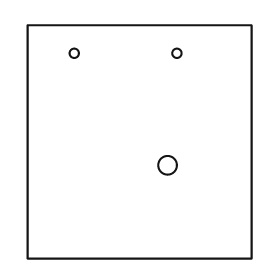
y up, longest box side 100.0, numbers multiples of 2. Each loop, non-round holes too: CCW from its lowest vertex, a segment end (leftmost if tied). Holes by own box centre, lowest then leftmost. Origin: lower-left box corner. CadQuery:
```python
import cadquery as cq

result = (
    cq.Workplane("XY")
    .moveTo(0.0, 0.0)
    .lineTo(96.0, 0.0)
    .lineTo(96.0, 100.0)
    .lineTo(0.0, 100.0)
    .close()
    .moveTo(60.0, 40.0)
    .circle(4.0)
    .moveTo(20.0, 88.0)
    .circle(2.0)
    .moveTo(64.0, 88.0)
    .circle(2.0)
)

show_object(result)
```